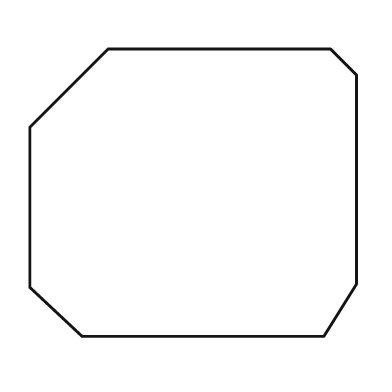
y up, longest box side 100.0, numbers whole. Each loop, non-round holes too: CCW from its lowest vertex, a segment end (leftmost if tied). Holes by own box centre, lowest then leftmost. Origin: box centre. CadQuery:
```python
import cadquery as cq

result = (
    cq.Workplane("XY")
    .moveTo(-34.0, -44.0)
    .lineTo(40.0, -44.0)
    .lineTo(50.0, -28.0)
    .lineTo(50.0, 36.0)
    .lineTo(42.0, 44.0)
    .lineTo(-26.0, 44.0)
    .lineTo(-50.0, 20.0)
    .lineTo(-50.0, -29.0)
    .close()
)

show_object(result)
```